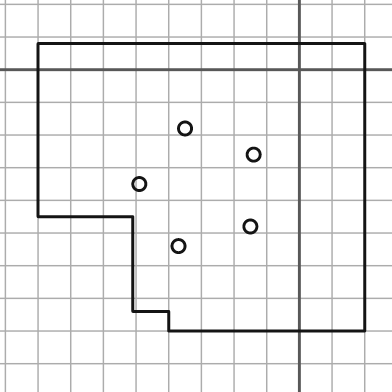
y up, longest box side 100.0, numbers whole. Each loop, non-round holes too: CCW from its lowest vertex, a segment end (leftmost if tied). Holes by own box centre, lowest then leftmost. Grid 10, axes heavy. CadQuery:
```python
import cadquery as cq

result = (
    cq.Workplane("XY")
    .moveTo(-40.0, -80.0)
    .lineTo(20.0, -80.0)
    .lineTo(20.0, 8.0)
    .lineTo(-80.0, 8.0)
    .lineTo(-80.0, -45.0)
    .lineTo(-51.0, -45.0)
    .lineTo(-51.0, -74.0)
    .lineTo(-40.0, -74.0)
    .close()
    .moveTo(-37.0, -54.0)
    .circle(2.0)
    .moveTo(-15.0, -48.0)
    .circle(2.0)
    .moveTo(-49.0, -35.0)
    .circle(2.0)
    .moveTo(-14.0, -26.0)
    .circle(2.0)
    .moveTo(-35.0, -18.0)
    .circle(2.0)
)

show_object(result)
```